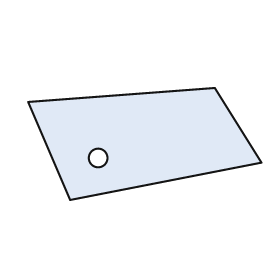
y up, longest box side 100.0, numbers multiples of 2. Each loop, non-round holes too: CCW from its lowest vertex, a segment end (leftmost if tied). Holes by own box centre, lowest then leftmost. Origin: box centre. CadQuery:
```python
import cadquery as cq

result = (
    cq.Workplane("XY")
    .moveTo(-32.0, -24.0)
    .lineTo(50.0, -8.0)
    .lineTo(30.0, 24.0)
    .lineTo(-50.0, 18.0)
    .close()
    .moveTo(-20.0, -6.0)
    .circle(4.0)
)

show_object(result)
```